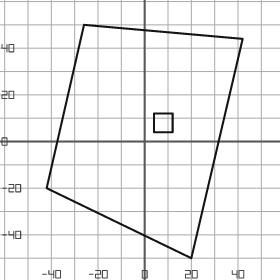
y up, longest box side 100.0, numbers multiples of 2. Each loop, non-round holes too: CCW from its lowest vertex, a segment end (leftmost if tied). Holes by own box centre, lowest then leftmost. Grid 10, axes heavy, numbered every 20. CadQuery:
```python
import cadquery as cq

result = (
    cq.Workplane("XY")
    .moveTo(20.0, -50.0)
    .lineTo(42.0, 44.0)
    .lineTo(-26.0, 50.0)
    .lineTo(-42.0, -20.0)
    .close()
    .moveTo(4.0, 4.0)
    .lineTo(12.0, 4.0)
    .lineTo(12.0, 12.0)
    .lineTo(4.0, 12.0)
    .close()
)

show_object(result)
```